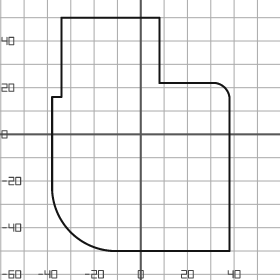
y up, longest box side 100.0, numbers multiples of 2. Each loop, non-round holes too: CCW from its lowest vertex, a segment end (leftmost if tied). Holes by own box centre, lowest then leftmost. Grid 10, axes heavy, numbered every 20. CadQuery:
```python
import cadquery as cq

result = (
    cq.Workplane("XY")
    .moveTo(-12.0, -50.0)
    .lineTo(38.0, -50.0)
    .lineTo(38.0, 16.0)
    .threePointArc((36.0, 20.0), (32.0, 22.0))
    .lineTo(8.0, 22.0)
    .lineTo(8.0, 50.0)
    .lineTo(-34.0, 50.0)
    .lineTo(-34.0, 16.0)
    .lineTo(-38.0, 16.0)
    .lineTo(-38.0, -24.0)
    .threePointArc((-30.0, -42.0), (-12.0, -50.0))
    .close()
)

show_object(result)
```